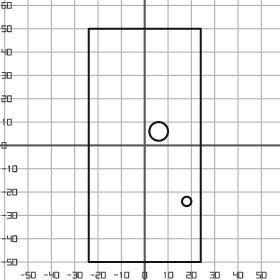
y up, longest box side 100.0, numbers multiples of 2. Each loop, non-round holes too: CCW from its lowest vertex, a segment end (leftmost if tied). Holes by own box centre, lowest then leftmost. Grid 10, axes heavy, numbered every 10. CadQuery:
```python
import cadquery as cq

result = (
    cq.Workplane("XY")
    .moveTo(-24.0, -50.0)
    .lineTo(24.0, -50.0)
    .lineTo(24.0, 50.0)
    .lineTo(-24.0, 50.0)
    .close()
    .moveTo(18.0, -24.0)
    .circle(2.0)
    .moveTo(6.0, 6.0)
    .circle(4.0)
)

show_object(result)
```